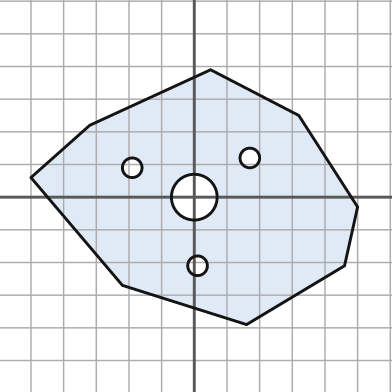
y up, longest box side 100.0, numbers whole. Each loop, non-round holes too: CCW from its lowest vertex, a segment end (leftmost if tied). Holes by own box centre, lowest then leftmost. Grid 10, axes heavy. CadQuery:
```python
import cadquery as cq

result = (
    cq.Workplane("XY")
    .moveTo(16.0, -39.0)
    .lineTo(46.0, -21.0)
    .lineTo(50.0, -3.0)
    .lineTo(32.0, 25.0)
    .lineTo(5.0, 39.0)
    .lineTo(-32.0, 22.0)
    .lineTo(-50.0, 6.0)
    .lineTo(-22.0, -27.0)
    .close()
    .moveTo(1.0, -21.0)
    .circle(3.0)
    .moveTo(0.0, 0.0)
    .circle(7.0)
    .moveTo(-19.0, 9.0)
    .circle(3.0)
    .moveTo(17.0, 12.0)
    .circle(3.0)
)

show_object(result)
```